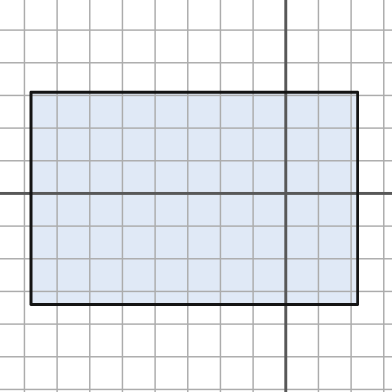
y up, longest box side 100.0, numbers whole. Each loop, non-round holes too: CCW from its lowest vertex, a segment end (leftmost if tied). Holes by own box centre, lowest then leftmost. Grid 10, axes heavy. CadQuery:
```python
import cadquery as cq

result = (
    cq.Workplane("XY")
    .moveTo(-78.0, -34.0)
    .lineTo(22.0, -34.0)
    .lineTo(22.0, 31.0)
    .lineTo(-78.0, 31.0)
    .close()
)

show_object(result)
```